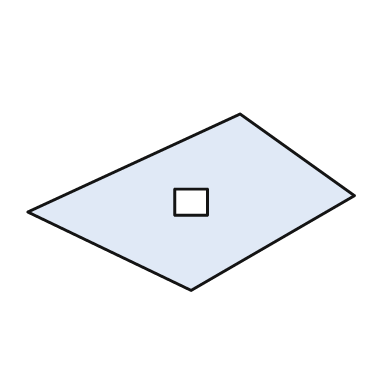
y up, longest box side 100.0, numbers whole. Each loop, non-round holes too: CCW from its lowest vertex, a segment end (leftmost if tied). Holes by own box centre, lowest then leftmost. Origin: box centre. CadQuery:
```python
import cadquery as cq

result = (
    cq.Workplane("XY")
    .moveTo(0.0, -27.0)
    .lineTo(50.0, 2.0)
    .lineTo(15.0, 27.0)
    .lineTo(-50.0, -3.0)
    .close()
    .moveTo(-5.0, -4.0)
    .lineTo(5.0, -4.0)
    .lineTo(5.0, 4.0)
    .lineTo(-5.0, 4.0)
    .close()
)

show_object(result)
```